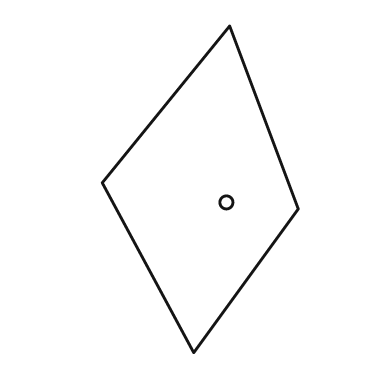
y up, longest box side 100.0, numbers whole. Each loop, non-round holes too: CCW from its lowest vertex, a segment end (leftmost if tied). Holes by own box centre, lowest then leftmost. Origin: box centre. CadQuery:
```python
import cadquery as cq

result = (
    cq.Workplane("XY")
    .moveTo(-2.0, -50.0)
    .lineTo(30.0, -6.0)
    .lineTo(9.0, 50.0)
    .lineTo(-30.0, 2.0)
    .close()
    .moveTo(8.0, -4.0)
    .circle(2.0)
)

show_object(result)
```